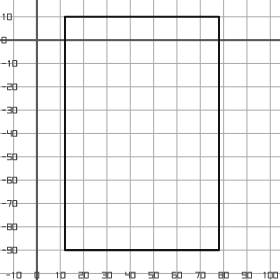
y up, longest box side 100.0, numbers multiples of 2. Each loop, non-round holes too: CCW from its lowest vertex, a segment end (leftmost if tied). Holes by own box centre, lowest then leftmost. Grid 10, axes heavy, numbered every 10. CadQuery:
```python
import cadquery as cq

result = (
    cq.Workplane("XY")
    .moveTo(12.0, -90.0)
    .lineTo(78.0, -90.0)
    .lineTo(78.0, 10.0)
    .lineTo(12.0, 10.0)
    .close()
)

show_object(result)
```